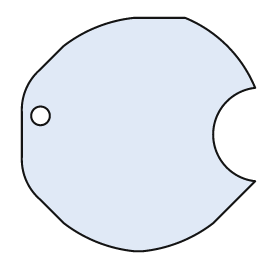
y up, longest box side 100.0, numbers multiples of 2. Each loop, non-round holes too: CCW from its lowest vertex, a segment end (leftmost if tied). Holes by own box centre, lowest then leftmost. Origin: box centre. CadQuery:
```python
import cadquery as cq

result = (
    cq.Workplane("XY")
    .moveTo(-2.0, -50.0)
    .lineTo(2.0, -50.0)
    .threePointArc((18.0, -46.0), (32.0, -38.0))
    .lineTo(50.0, -20.0)
    .threePointArc((32.0, 0.0), (50.0, 20.0))
    .threePointArc((38.0, 38.0), (20.0, 50.0))
    .lineTo(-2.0, 50.0)
    .threePointArc((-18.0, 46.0), (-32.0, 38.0))
    .lineTo(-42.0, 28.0)
    .threePointArc((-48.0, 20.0), (-50.0, 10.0))
    .lineTo(-50.0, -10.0)
    .threePointArc((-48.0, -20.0), (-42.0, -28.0))
    .lineTo(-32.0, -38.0)
    .threePointArc((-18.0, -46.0), (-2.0, -50.0))
    .close()
    .moveTo(-42.0, 8.0)
    .circle(4.0)
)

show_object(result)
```